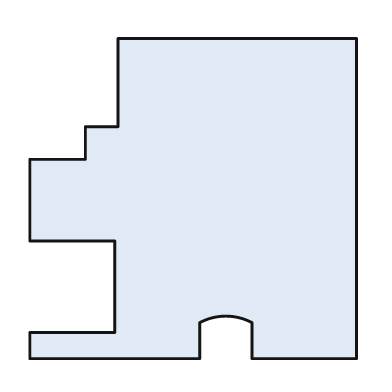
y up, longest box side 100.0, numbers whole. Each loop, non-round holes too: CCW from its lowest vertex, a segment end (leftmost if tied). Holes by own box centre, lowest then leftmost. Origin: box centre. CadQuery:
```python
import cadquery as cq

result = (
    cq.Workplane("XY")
    .moveTo(-50.0, -49.0)
    .lineTo(2.0, -49.0)
    .lineTo(2.0, -38.0)
    .threePointArc((10.0, -36.0), (18.0, -38.0))
    .lineTo(18.0, -49.0)
    .lineTo(50.0, -49.0)
    .lineTo(50.0, 49.0)
    .lineTo(-23.0, 49.0)
    .lineTo(-23.0, 22.0)
    .lineTo(-33.0, 22.0)
    .lineTo(-33.0, 12.0)
    .lineTo(-50.0, 12.0)
    .lineTo(-50.0, -13.0)
    .lineTo(-24.0, -13.0)
    .lineTo(-24.0, -41.0)
    .lineTo(-50.0, -41.0)
    .close()
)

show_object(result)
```